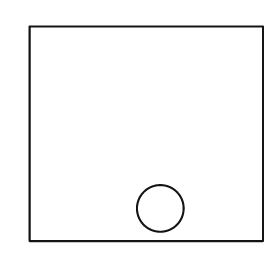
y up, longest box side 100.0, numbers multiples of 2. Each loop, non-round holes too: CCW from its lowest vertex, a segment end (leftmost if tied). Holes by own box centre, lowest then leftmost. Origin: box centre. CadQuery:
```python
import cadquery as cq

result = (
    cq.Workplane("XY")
    .moveTo(-50.0, -46.0)
    .lineTo(50.0, -46.0)
    .lineTo(50.0, 46.0)
    .lineTo(-50.0, 46.0)
    .close()
    .moveTo(6.0, -32.0)
    .circle(10.0)
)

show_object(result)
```